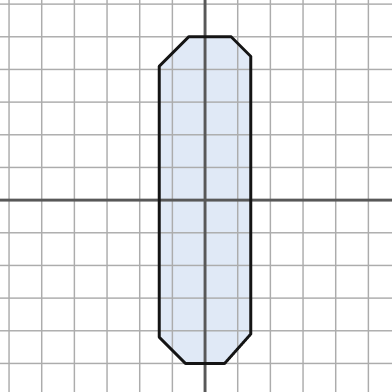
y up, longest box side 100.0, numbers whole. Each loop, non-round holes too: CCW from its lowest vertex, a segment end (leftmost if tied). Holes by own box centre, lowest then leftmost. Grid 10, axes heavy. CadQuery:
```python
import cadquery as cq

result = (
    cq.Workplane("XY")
    .moveTo(-6.0, -50.0)
    .lineTo(6.0, -50.0)
    .lineTo(14.0, -41.0)
    .lineTo(14.0, 44.0)
    .lineTo(8.0, 50.0)
    .lineTo(-5.0, 50.0)
    .lineTo(-14.0, 41.0)
    .lineTo(-14.0, -42.0)
    .close()
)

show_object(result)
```